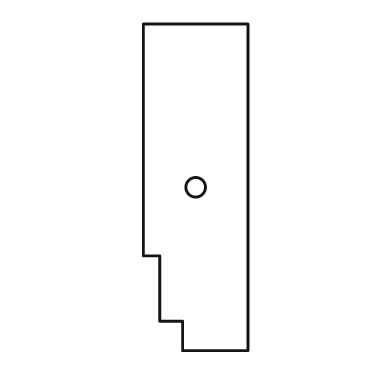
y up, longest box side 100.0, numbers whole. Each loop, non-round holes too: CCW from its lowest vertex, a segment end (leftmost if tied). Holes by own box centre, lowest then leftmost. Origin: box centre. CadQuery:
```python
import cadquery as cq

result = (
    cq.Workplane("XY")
    .moveTo(-4.0, -50.0)
    .lineTo(16.0, -50.0)
    .lineTo(16.0, 50.0)
    .lineTo(-16.0, 50.0)
    .lineTo(-16.0, -21.0)
    .lineTo(-11.0, -21.0)
    .lineTo(-11.0, -41.0)
    .lineTo(-4.0, -41.0)
    .close()
    .moveTo(0.0, 0.0)
    .circle(3.0)
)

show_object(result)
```